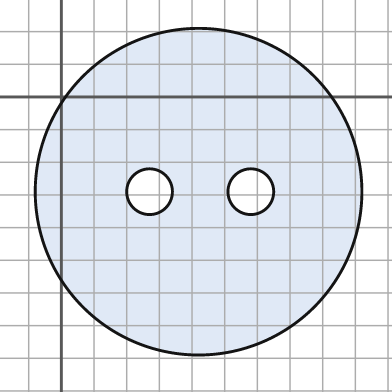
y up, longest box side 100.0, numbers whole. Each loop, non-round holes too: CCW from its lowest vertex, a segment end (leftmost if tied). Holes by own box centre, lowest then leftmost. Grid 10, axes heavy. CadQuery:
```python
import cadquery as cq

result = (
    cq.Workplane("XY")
    .moveTo(42.0, -29.0)
    .circle(50.0)
    .moveTo(27.0, -29.0)
    .circle(7.0)
    .moveTo(58.0, -29.0)
    .circle(7.0)
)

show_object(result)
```